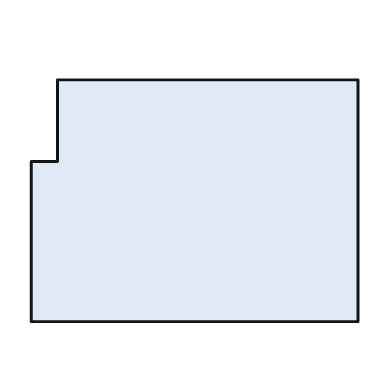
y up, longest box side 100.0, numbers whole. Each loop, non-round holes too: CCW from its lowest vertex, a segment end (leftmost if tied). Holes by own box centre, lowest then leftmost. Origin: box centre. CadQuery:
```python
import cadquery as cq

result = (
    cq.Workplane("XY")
    .moveTo(-50.0, -37.0)
    .lineTo(50.0, -37.0)
    .lineTo(50.0, 37.0)
    .lineTo(-42.0, 37.0)
    .lineTo(-42.0, 12.0)
    .lineTo(-50.0, 12.0)
    .close()
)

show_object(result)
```